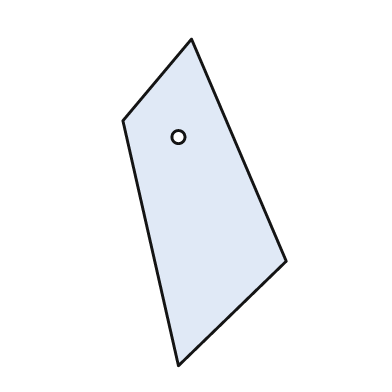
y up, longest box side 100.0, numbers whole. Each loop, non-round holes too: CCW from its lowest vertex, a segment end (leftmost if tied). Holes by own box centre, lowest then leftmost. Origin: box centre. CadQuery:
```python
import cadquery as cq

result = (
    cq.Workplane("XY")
    .moveTo(-8.0, -50.0)
    .lineTo(25.0, -18.0)
    .lineTo(-4.0, 50.0)
    .lineTo(-25.0, 25.0)
    .close()
    .moveTo(-8.0, 20.0)
    .circle(2.0)
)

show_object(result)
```